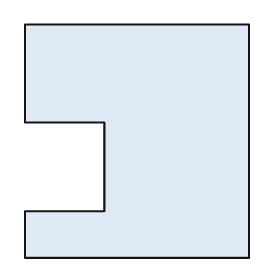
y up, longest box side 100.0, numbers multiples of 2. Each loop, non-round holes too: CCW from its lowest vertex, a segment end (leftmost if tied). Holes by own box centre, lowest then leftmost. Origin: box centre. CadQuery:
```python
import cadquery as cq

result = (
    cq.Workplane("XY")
    .moveTo(-48.0, -50.0)
    .lineTo(48.0, -50.0)
    .lineTo(48.0, 50.0)
    .lineTo(-48.0, 50.0)
    .lineTo(-48.0, 8.0)
    .lineTo(-14.0, 8.0)
    .lineTo(-14.0, -30.0)
    .lineTo(-48.0, -30.0)
    .close()
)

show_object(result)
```